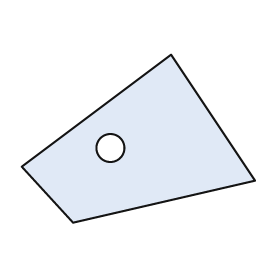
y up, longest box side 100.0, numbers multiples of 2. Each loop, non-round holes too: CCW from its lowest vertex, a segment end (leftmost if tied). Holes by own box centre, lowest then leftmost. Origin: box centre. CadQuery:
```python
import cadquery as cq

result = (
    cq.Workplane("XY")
    .moveTo(-28.0, -36.0)
    .lineTo(50.0, -18.0)
    .lineTo(14.0, 36.0)
    .lineTo(-50.0, -12.0)
    .close()
    .moveTo(-12.0, -4.0)
    .circle(6.0)
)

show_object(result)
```